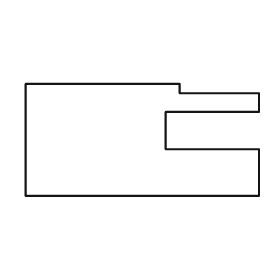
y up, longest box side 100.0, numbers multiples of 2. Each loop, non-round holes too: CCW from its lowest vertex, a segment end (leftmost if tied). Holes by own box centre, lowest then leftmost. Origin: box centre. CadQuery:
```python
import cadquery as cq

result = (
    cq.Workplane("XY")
    .moveTo(-50.0, -24.0)
    .lineTo(50.0, -24.0)
    .lineTo(50.0, -4.0)
    .lineTo(10.0, -4.0)
    .lineTo(10.0, 12.0)
    .lineTo(50.0, 12.0)
    .lineTo(50.0, 20.0)
    .lineTo(16.0, 20.0)
    .lineTo(16.0, 24.0)
    .lineTo(-50.0, 24.0)
    .close()
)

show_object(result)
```